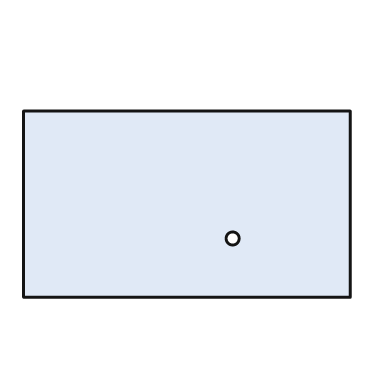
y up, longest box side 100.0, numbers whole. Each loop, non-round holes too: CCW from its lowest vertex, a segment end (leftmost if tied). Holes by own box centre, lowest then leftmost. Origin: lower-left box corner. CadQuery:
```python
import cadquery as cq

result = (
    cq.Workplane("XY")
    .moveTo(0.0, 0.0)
    .lineTo(100.0, 0.0)
    .lineTo(100.0, 57.0)
    .lineTo(0.0, 57.0)
    .close()
    .moveTo(64.0, 18.0)
    .circle(2.0)
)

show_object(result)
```